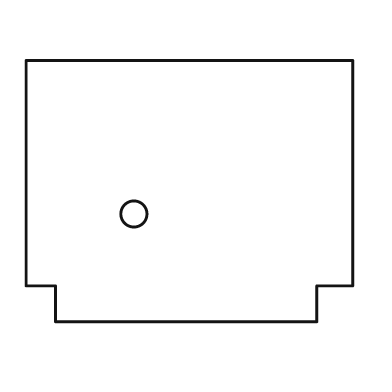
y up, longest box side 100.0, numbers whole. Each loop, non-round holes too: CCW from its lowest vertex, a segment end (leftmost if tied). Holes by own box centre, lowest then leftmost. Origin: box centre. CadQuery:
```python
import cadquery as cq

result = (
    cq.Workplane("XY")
    .moveTo(-41.0, -40.0)
    .lineTo(39.0, -40.0)
    .lineTo(39.0, -29.0)
    .lineTo(50.0, -29.0)
    .lineTo(50.0, 40.0)
    .lineTo(-50.0, 40.0)
    .lineTo(-50.0, -29.0)
    .lineTo(-41.0, -29.0)
    .close()
    .moveTo(-17.0, -7.0)
    .circle(4.0)
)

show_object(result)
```